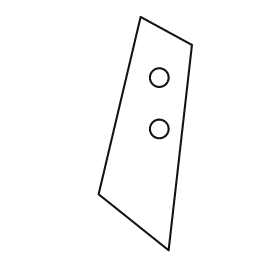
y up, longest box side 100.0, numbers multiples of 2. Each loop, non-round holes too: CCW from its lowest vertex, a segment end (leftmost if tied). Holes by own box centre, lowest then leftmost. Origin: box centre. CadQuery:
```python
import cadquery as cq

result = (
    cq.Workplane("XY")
    .moveTo(10.0, -50.0)
    .lineTo(20.0, 38.0)
    .lineTo(-2.0, 50.0)
    .lineTo(-20.0, -26.0)
    .close()
    .moveTo(6.0, 2.0)
    .circle(4.0)
    .moveTo(6.0, 24.0)
    .circle(4.0)
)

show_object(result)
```